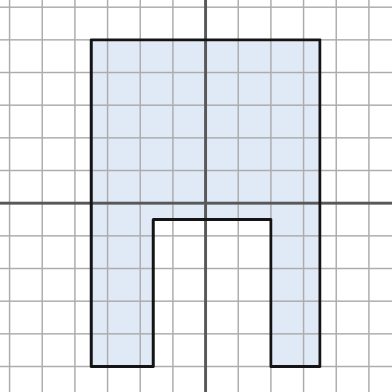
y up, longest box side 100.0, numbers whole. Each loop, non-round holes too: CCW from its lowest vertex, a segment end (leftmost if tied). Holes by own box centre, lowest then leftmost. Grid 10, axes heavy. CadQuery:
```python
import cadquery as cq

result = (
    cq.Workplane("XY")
    .moveTo(-35.0, -50.0)
    .lineTo(-16.0, -50.0)
    .lineTo(-16.0, -5.0)
    .lineTo(20.0, -5.0)
    .lineTo(20.0, -50.0)
    .lineTo(35.0, -50.0)
    .lineTo(35.0, 50.0)
    .lineTo(-35.0, 50.0)
    .close()
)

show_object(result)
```